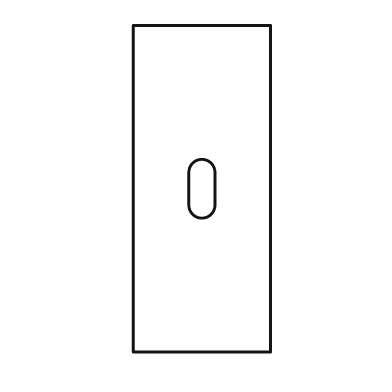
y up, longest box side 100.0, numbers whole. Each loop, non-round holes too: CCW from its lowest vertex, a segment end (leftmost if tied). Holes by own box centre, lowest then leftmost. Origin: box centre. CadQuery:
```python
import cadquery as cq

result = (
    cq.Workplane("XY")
    .moveTo(-21.0, -50.0)
    .lineTo(21.0, -50.0)
    .lineTo(21.0, 50.0)
    .lineTo(-21.0, 50.0)
    .close()
    .moveTo(-4.0, -5.0)
    .threePointArc((0.0, -9.0), (4.0, -5.0))
    .lineTo(4.0, 5.0)
    .threePointArc((0.0, 9.0), (-4.0, 5.0))
    .close()
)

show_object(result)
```